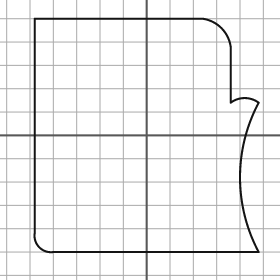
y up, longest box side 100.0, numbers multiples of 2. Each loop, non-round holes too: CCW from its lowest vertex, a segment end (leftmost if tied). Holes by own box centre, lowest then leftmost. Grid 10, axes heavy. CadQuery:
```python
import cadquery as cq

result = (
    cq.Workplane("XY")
    .moveTo(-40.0, -50.0)
    .lineTo(48.0, -50.0)
    .threePointArc((40.0, -18.0), (48.0, 14.0))
    .threePointArc((42.0, 16.0), (36.0, 14.0))
    .lineTo(36.0, 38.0)
    .threePointArc((32.0, 46.0), (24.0, 50.0))
    .lineTo(-48.0, 50.0)
    .lineTo(-48.0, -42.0)
    .threePointArc((-46.0, -48.0), (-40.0, -50.0))
    .close()
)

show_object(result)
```